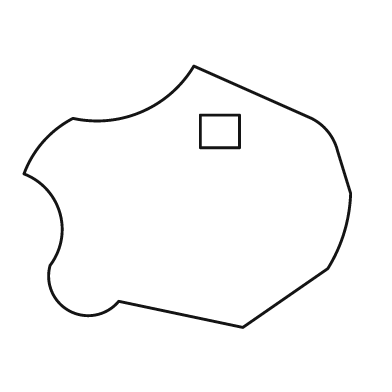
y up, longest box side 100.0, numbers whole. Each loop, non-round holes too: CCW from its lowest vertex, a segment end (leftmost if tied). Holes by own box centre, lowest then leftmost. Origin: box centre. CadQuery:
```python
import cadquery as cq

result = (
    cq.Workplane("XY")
    .moveTo(17.0, -40.0)
    .lineTo(43.0, -22.0)
    .threePointArc((48.0, -11.0), (50.0, 1.0))
    .lineTo(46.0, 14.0)
    .threePointArc((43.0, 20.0), (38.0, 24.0))
    .lineTo(2.0, 40.0)
    .threePointArc((-14.0, 26.0), (-35.0, 24.0))
    .threePointArc((-44.0, 17.0), (-50.0, 7.0))
    .threePointArc((-39.0, -5.0), (-42.0, -21.0))
    .threePointArc((-36.0, -35.0), (-21.0, -32.0))
    .close()
    .moveTo(4.0, 15.0)
    .lineTo(16.0, 15.0)
    .lineTo(16.0, 25.0)
    .lineTo(4.0, 25.0)
    .close()
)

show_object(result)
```